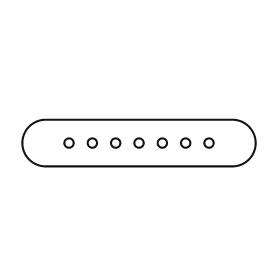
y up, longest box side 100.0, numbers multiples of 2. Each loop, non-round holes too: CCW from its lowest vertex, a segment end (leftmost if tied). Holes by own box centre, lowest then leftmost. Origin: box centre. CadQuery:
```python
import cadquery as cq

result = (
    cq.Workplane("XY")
    .moveTo(-40.0, -10.0)
    .lineTo(40.0, -10.0)
    .threePointArc((50.0, 0.0), (40.0, 10.0))
    .lineTo(-40.0, 10.0)
    .threePointArc((-50.0, 0.0), (-40.0, -10.0))
    .close()
    .moveTo(-30.0, 0.0)
    .circle(2.0)
    .moveTo(-20.0, 0.0)
    .circle(2.0)
    .moveTo(-10.0, 0.0)
    .circle(2.0)
    .moveTo(0.0, 0.0)
    .circle(2.0)
    .moveTo(10.0, 0.0)
    .circle(2.0)
    .moveTo(20.0, 0.0)
    .circle(2.0)
    .moveTo(30.0, 0.0)
    .circle(2.0)
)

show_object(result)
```